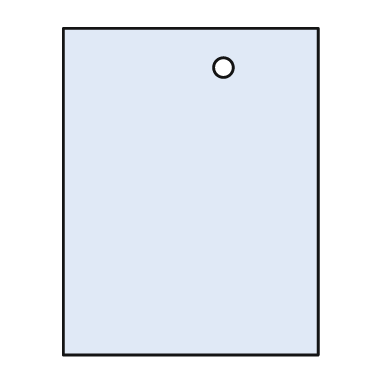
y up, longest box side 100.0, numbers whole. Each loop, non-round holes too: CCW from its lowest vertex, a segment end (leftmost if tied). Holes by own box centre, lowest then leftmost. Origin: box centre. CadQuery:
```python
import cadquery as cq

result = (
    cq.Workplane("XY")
    .moveTo(-39.0, -50.0)
    .lineTo(39.0, -50.0)
    .lineTo(39.0, 50.0)
    .lineTo(-39.0, 50.0)
    .close()
    .moveTo(10.0, 38.0)
    .circle(3.0)
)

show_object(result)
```